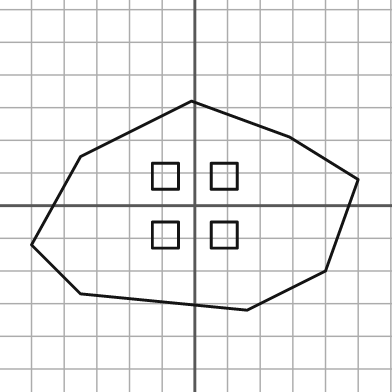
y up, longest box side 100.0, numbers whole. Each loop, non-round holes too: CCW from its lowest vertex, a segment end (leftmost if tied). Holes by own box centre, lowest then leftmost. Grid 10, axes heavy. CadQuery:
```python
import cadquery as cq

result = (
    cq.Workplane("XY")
    .moveTo(16.0, -32.0)
    .lineTo(40.0, -20.0)
    .lineTo(50.0, 8.0)
    .lineTo(29.0, 21.0)
    .lineTo(-1.0, 32.0)
    .lineTo(-35.0, 15.0)
    .lineTo(-50.0, -12.0)
    .lineTo(-35.0, -27.0)
    .close()
    .moveTo(-13.0, -13.0)
    .lineTo(-5.0, -13.0)
    .lineTo(-5.0, -5.0)
    .lineTo(-13.0, -5.0)
    .close()
    .moveTo(5.0, -13.0)
    .lineTo(13.0, -13.0)
    .lineTo(13.0, -5.0)
    .lineTo(5.0, -5.0)
    .close()
    .moveTo(-13.0, 5.0)
    .lineTo(-5.0, 5.0)
    .lineTo(-5.0, 13.0)
    .lineTo(-13.0, 13.0)
    .close()
    .moveTo(5.0, 5.0)
    .lineTo(13.0, 5.0)
    .lineTo(13.0, 13.0)
    .lineTo(5.0, 13.0)
    .close()
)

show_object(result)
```